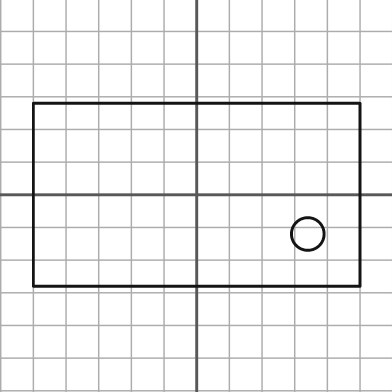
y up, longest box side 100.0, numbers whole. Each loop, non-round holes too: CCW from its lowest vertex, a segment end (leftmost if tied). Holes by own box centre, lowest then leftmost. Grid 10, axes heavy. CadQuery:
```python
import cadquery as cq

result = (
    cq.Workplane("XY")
    .moveTo(-50.0, -28.0)
    .lineTo(50.0, -28.0)
    .lineTo(50.0, 28.0)
    .lineTo(-50.0, 28.0)
    .close()
    .moveTo(34.0, -12.0)
    .circle(5.0)
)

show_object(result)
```